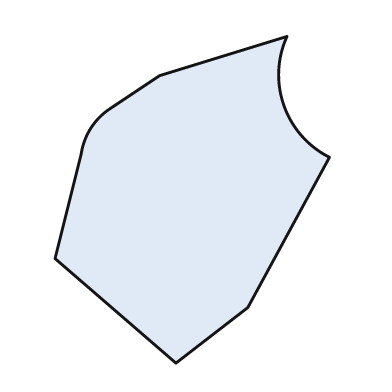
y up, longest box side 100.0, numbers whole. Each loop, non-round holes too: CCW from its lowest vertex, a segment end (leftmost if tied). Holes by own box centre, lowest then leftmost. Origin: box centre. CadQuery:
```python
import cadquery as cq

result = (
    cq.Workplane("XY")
    .moveTo(-5.0, -50.0)
    .lineTo(17.0, -33.0)
    .lineTo(42.0, 13.0)
    .threePointArc((28.0, 29.0), (29.0, 50.0))
    .lineTo(-10.0, 38.0)
    .lineTo(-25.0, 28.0)
    .threePointArc((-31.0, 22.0), (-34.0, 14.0))
    .lineTo(-42.0, -18.0)
    .close()
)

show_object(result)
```